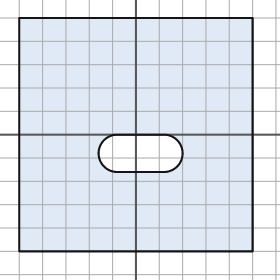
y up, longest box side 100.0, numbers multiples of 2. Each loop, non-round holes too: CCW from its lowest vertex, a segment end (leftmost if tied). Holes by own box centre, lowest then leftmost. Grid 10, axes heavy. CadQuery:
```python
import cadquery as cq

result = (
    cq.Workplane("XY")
    .moveTo(-50.0, -50.0)
    .lineTo(50.0, -50.0)
    .lineTo(50.0, 50.0)
    .lineTo(-50.0, 50.0)
    .close()
    .moveTo(-8.0, -16.0)
    .lineTo(12.0, -16.0)
    .threePointArc((20.0, -8.0), (12.0, 0.0))
    .lineTo(-8.0, 0.0)
    .threePointArc((-16.0, -8.0), (-8.0, -16.0))
    .close()
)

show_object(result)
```